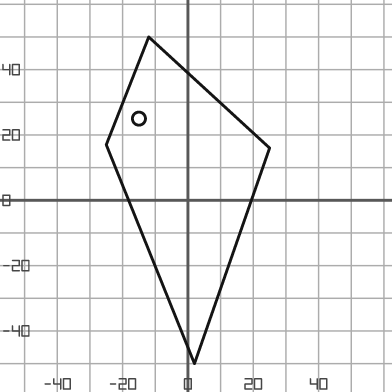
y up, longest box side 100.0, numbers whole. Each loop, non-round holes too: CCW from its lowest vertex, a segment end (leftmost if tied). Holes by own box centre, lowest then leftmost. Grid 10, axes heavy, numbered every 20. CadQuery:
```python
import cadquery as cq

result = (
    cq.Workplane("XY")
    .moveTo(2.0, -50.0)
    .lineTo(25.0, 16.0)
    .lineTo(-12.0, 50.0)
    .lineTo(-25.0, 17.0)
    .close()
    .moveTo(-15.0, 25.0)
    .circle(2.0)
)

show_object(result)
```